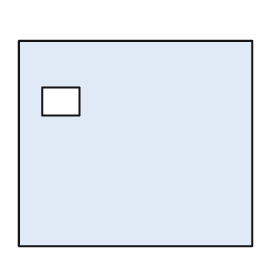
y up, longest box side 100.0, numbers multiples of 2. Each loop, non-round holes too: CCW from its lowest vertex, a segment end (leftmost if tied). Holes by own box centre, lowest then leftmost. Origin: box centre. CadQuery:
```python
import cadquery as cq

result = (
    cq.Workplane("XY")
    .moveTo(-50.0, -44.0)
    .lineTo(50.0, -44.0)
    .lineTo(50.0, 44.0)
    .lineTo(-50.0, 44.0)
    .close()
    .moveTo(-40.0, 12.0)
    .lineTo(-24.0, 12.0)
    .lineTo(-24.0, 24.0)
    .lineTo(-40.0, 24.0)
    .close()
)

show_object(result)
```